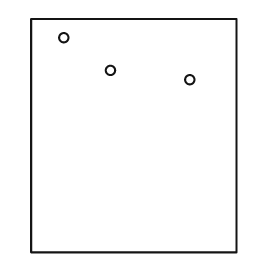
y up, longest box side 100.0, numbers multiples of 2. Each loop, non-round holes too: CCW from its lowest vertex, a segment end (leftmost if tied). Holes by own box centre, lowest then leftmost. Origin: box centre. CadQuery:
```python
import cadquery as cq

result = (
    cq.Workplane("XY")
    .moveTo(-44.0, -50.0)
    .lineTo(44.0, -50.0)
    .lineTo(44.0, 50.0)
    .lineTo(-44.0, 50.0)
    .close()
    .moveTo(24.0, 24.0)
    .circle(2.0)
    .moveTo(-10.0, 28.0)
    .circle(2.0)
    .moveTo(-30.0, 42.0)
    .circle(2.0)
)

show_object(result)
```